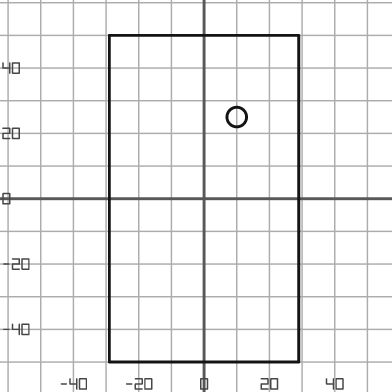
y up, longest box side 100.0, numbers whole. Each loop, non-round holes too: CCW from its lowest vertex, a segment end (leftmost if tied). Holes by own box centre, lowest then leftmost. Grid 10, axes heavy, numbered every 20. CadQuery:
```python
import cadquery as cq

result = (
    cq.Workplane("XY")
    .moveTo(-29.0, -50.0)
    .lineTo(29.0, -50.0)
    .lineTo(29.0, 50.0)
    .lineTo(-29.0, 50.0)
    .close()
    .moveTo(10.0, 25.0)
    .circle(3.0)
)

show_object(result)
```